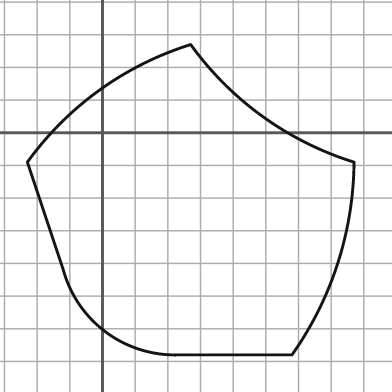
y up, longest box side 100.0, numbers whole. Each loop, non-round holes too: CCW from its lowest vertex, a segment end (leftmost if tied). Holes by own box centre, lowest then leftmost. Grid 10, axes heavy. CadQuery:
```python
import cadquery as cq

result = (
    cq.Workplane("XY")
    .moveTo(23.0, -68.0)
    .lineTo(58.0, -68.0)
    .threePointArc((72.0, -40.0), (77.0, -9.0))
    .threePointArc((49.0, 5.0), (27.0, 27.0))
    .threePointArc((-1.0, 13.0), (-23.0, -9.0))
    .lineTo(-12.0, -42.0)
    .threePointArc((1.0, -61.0), (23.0, -68.0))
    .close()
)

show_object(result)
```